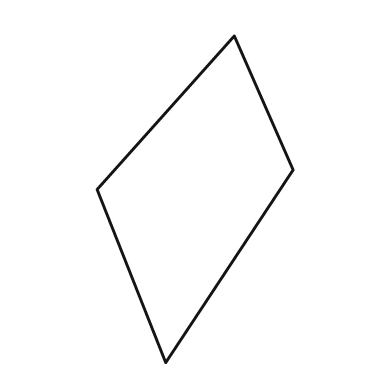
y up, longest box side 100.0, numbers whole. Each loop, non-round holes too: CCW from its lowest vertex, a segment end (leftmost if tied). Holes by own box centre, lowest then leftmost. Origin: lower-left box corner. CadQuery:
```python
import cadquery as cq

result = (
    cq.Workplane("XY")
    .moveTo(21.0, 0.0)
    .lineTo(60.0, 59.0)
    .lineTo(42.0, 100.0)
    .lineTo(0.0, 53.0)
    .close()
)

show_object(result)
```